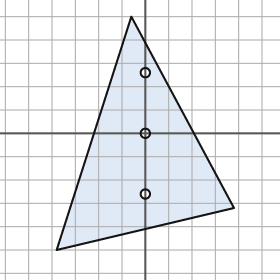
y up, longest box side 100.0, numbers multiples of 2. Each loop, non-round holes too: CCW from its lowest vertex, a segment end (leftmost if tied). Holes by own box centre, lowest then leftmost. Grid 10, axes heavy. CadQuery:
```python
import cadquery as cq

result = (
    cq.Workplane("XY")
    .moveTo(-38.0, -50.0)
    .lineTo(38.0, -32.0)
    .lineTo(-6.0, 50.0)
    .close()
    .moveTo(0.0, -26.0)
    .circle(2.0)
    .moveTo(0.0, 0.0)
    .circle(2.0)
    .moveTo(0.0, 26.0)
    .circle(2.0)
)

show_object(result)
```